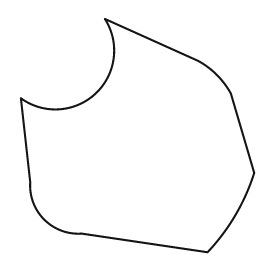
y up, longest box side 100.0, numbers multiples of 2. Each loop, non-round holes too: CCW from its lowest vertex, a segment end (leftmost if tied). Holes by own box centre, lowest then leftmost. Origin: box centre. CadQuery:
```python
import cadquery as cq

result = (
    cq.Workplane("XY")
    .moveTo(30.0, -50.0)
    .threePointArc((42.0, -34.0), (50.0, -16.0))
    .lineTo(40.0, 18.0)
    .threePointArc((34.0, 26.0), (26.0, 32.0))
    .lineTo(-14.0, 50.0)
    .threePointArc((-18.0, 18.0), (-50.0, 16.0))
    .lineTo(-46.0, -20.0)
    .threePointArc((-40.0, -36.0), (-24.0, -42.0))
    .close()
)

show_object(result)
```